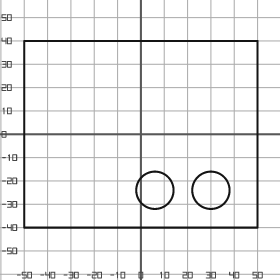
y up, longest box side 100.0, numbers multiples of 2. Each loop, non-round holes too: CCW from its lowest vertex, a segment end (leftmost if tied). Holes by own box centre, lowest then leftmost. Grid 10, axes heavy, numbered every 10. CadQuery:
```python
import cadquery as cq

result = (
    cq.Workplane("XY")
    .moveTo(-50.0, -40.0)
    .lineTo(50.0, -40.0)
    .lineTo(50.0, 40.0)
    .lineTo(-50.0, 40.0)
    .close()
    .moveTo(6.0, -24.0)
    .circle(8.0)
    .moveTo(30.0, -24.0)
    .circle(8.0)
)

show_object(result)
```